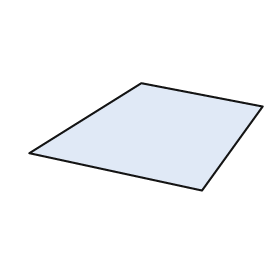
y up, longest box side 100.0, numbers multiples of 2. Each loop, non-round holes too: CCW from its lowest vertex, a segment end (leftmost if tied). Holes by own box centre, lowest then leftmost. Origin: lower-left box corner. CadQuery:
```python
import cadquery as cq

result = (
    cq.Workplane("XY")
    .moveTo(74.0, 0.0)
    .lineTo(100.0, 36.0)
    .lineTo(48.0, 46.0)
    .lineTo(0.0, 16.0)
    .close()
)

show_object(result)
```